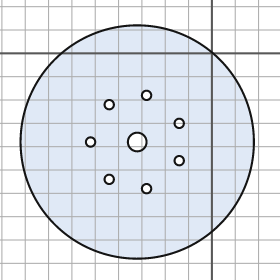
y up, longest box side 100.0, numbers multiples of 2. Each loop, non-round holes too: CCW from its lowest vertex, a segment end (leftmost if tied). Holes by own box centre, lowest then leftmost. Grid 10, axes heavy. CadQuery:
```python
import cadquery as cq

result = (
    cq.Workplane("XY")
    .moveTo(-32.0, -38.0)
    .circle(50.0)
    .moveTo(-28.0, -58.0)
    .circle(2.0)
    .moveTo(-44.0, -54.0)
    .circle(2.0)
    .moveTo(-14.0, -46.0)
    .circle(2.0)
    .moveTo(-52.0, -38.0)
    .circle(2.0)
    .moveTo(-32.0, -38.0)
    .circle(4.0)
    .moveTo(-14.0, -30.0)
    .circle(2.0)
    .moveTo(-44.0, -22.0)
    .circle(2.0)
    .moveTo(-28.0, -18.0)
    .circle(2.0)
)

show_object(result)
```